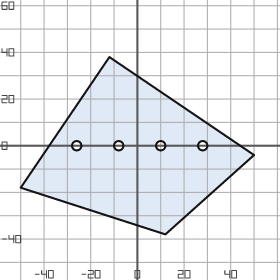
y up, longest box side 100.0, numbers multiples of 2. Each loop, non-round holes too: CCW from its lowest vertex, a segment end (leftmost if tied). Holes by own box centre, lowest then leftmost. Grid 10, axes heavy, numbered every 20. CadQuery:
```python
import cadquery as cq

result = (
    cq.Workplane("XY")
    .moveTo(12.0, -38.0)
    .lineTo(50.0, -4.0)
    .lineTo(-12.0, 38.0)
    .lineTo(-50.0, -18.0)
    .close()
    .moveTo(-26.0, 0.0)
    .circle(2.0)
    .moveTo(-8.0, 0.0)
    .circle(2.0)
    .moveTo(10.0, 0.0)
    .circle(2.0)
    .moveTo(28.0, 0.0)
    .circle(2.0)
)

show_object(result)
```